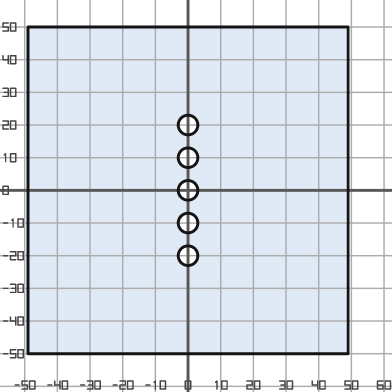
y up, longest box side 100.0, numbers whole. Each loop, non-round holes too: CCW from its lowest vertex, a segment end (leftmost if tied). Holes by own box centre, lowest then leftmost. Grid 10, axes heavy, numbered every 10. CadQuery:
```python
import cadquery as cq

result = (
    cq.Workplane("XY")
    .moveTo(-49.0, -50.0)
    .lineTo(49.0, -50.0)
    .lineTo(49.0, 50.0)
    .lineTo(-49.0, 50.0)
    .close()
    .moveTo(0.0, -20.0)
    .circle(3.0)
    .moveTo(0.0, -10.0)
    .circle(3.0)
    .moveTo(0.0, 0.0)
    .circle(3.0)
    .moveTo(0.0, 10.0)
    .circle(3.0)
    .moveTo(0.0, 20.0)
    .circle(3.0)
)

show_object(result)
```